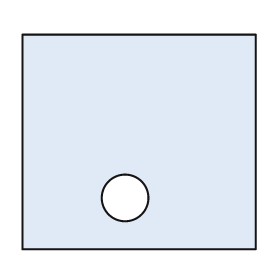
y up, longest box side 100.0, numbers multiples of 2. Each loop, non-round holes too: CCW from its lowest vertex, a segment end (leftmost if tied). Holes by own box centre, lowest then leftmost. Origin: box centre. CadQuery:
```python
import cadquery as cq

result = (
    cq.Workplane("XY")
    .moveTo(-50.0, -46.0)
    .lineTo(50.0, -46.0)
    .lineTo(50.0, 46.0)
    .lineTo(-50.0, 46.0)
    .close()
    .moveTo(-6.0, -24.0)
    .circle(10.0)
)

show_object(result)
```